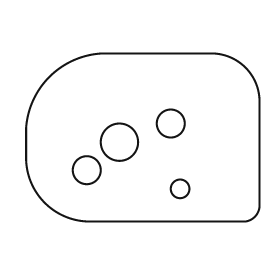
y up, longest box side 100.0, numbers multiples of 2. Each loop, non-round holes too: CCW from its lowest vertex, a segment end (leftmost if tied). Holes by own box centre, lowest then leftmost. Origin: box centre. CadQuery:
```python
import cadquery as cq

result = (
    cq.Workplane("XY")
    .moveTo(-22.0, -36.0)
    .lineTo(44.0, -36.0)
    .threePointArc((48.0, -34.0), (50.0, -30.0))
    .lineTo(50.0, 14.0)
    .threePointArc((44.0, 30.0), (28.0, 36.0))
    .lineTo(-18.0, 36.0)
    .threePointArc((-40.0, 26.0), (-50.0, 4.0))
    .lineTo(-50.0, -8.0)
    .threePointArc((-42.0, -28.0), (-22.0, -36.0))
    .close()
    .moveTo(16.0, -22.0)
    .circle(4.0)
    .moveTo(-24.0, -14.0)
    .circle(6.0)
    .moveTo(-10.0, -2.0)
    .circle(8.0)
    .moveTo(12.0, 6.0)
    .circle(6.0)
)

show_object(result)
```